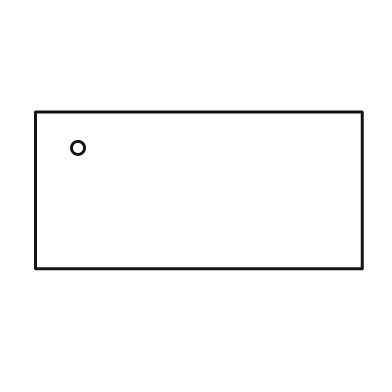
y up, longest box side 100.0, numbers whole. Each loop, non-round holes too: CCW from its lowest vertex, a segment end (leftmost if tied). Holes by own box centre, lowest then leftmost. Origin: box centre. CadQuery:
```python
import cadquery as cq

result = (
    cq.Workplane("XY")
    .moveTo(-50.0, -24.0)
    .lineTo(50.0, -24.0)
    .lineTo(50.0, 24.0)
    .lineTo(-50.0, 24.0)
    .close()
    .moveTo(-37.0, 13.0)
    .circle(2.0)
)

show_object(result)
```